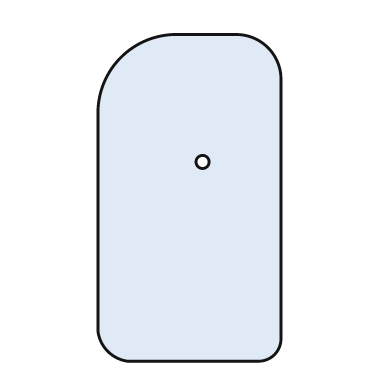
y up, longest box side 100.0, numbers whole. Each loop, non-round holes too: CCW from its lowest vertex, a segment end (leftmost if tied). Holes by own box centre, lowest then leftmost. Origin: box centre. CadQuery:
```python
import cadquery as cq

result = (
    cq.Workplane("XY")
    .moveTo(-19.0, -50.0)
    .lineTo(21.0, -50.0)
    .threePointArc((26.0, -48.0), (28.0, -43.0))
    .lineTo(28.0, 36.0)
    .threePointArc((24.0, 46.0), (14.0, 50.0))
    .lineTo(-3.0, 50.0)
    .threePointArc((-21.0, 43.0), (-28.0, 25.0))
    .lineTo(-28.0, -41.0)
    .threePointArc((-25.0, -47.0), (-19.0, -50.0))
    .close()
    .moveTo(4.0, 11.0)
    .circle(2.0)
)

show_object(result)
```